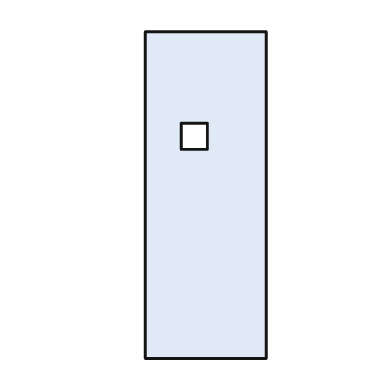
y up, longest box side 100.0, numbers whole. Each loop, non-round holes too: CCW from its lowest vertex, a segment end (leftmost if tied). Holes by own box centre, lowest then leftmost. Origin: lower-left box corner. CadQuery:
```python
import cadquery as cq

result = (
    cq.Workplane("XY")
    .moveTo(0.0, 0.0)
    .lineTo(37.0, 0.0)
    .lineTo(37.0, 100.0)
    .lineTo(0.0, 100.0)
    .close()
    .moveTo(11.0, 64.0)
    .lineTo(19.0, 64.0)
    .lineTo(19.0, 72.0)
    .lineTo(11.0, 72.0)
    .close()
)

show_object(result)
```